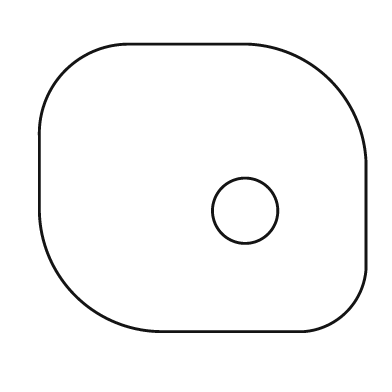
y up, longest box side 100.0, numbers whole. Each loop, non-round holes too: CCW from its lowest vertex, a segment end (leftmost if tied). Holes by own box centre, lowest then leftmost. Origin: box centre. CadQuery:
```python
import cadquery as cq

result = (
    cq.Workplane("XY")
    .moveTo(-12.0, -44.0)
    .lineTo(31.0, -44.0)
    .threePointArc((44.0, -38.0), (50.0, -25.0))
    .lineTo(50.0, 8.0)
    .threePointArc((39.0, 33.0), (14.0, 44.0))
    .lineTo(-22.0, 44.0)
    .threePointArc((-42.0, 36.0), (-50.0, 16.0))
    .lineTo(-50.0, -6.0)
    .threePointArc((-39.0, -33.0), (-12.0, -44.0))
    .close()
    .moveTo(13.0, -7.0)
    .circle(10.0)
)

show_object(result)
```